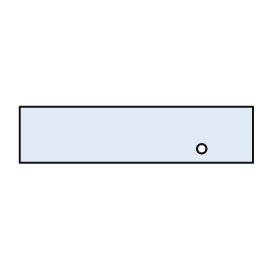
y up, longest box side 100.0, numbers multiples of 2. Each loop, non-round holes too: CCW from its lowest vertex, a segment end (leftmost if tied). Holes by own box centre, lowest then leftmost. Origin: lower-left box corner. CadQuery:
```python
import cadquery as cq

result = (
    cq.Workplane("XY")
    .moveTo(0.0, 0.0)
    .lineTo(100.0, 0.0)
    .lineTo(100.0, 24.0)
    .lineTo(0.0, 24.0)
    .close()
    .moveTo(78.0, 6.0)
    .circle(2.0)
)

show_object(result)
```